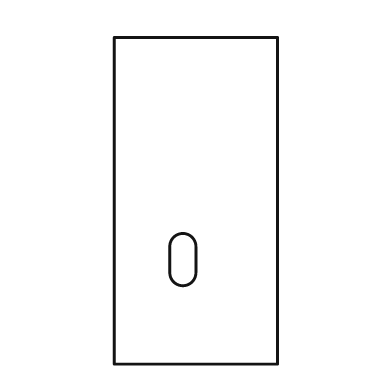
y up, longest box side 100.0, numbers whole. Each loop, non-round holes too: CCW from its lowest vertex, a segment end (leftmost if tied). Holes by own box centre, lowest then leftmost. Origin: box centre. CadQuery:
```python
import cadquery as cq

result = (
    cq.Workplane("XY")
    .moveTo(-25.0, -50.0)
    .lineTo(25.0, -50.0)
    .lineTo(25.0, 50.0)
    .lineTo(-25.0, 50.0)
    .close()
    .moveTo(-8.0, -22.0)
    .threePointArc((-4.0, -26.0), (0.0, -22.0))
    .lineTo(0.0, -14.0)
    .threePointArc((-4.0, -10.0), (-8.0, -14.0))
    .close()
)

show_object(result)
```